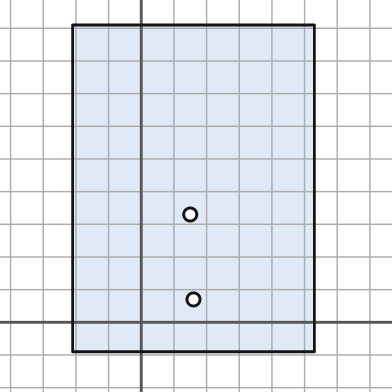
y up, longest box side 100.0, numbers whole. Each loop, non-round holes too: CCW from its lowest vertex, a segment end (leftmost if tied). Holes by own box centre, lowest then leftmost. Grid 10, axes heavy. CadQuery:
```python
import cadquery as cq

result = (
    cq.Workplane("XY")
    .moveTo(-21.0, -9.0)
    .lineTo(53.0, -9.0)
    .lineTo(53.0, 91.0)
    .lineTo(-21.0, 91.0)
    .close()
    .moveTo(16.0, 7.0)
    .circle(2.0)
    .moveTo(15.0, 33.0)
    .circle(2.0)
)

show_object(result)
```